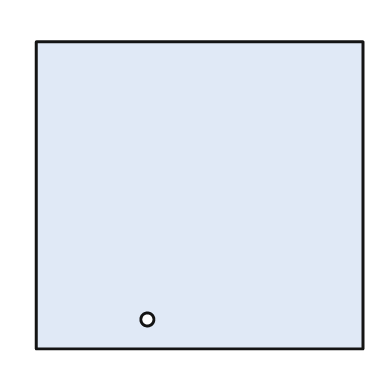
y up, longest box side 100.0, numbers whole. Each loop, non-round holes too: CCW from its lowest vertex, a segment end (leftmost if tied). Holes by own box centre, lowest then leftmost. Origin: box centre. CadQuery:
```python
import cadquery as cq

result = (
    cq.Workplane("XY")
    .moveTo(-50.0, -47.0)
    .lineTo(50.0, -47.0)
    .lineTo(50.0, 47.0)
    .lineTo(-50.0, 47.0)
    .close()
    .moveTo(-16.0, -38.0)
    .circle(2.0)
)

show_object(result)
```